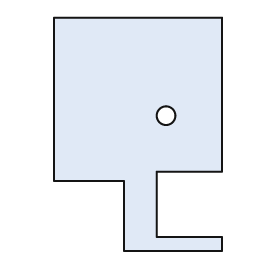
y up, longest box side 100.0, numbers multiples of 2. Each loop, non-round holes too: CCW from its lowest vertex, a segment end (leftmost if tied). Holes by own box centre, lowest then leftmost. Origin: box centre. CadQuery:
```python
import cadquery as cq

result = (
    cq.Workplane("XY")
    .moveTo(-6.0, -50.0)
    .lineTo(36.0, -50.0)
    .lineTo(36.0, -44.0)
    .lineTo(8.0, -44.0)
    .lineTo(8.0, -16.0)
    .lineTo(36.0, -16.0)
    .lineTo(36.0, 50.0)
    .lineTo(-36.0, 50.0)
    .lineTo(-36.0, -20.0)
    .lineTo(-6.0, -20.0)
    .close()
    .moveTo(12.0, 8.0)
    .circle(4.0)
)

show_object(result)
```